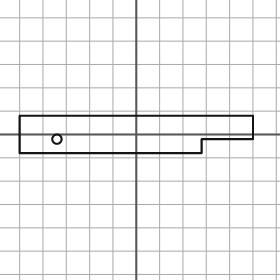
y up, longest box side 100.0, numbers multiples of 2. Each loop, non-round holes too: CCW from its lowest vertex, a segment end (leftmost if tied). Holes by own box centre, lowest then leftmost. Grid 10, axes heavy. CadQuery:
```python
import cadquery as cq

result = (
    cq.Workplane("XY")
    .moveTo(-50.0, -8.0)
    .lineTo(28.0, -8.0)
    .lineTo(28.0, -2.0)
    .lineTo(50.0, -2.0)
    .lineTo(50.0, 8.0)
    .lineTo(-50.0, 8.0)
    .close()
    .moveTo(-34.0, -2.0)
    .circle(2.0)
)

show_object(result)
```